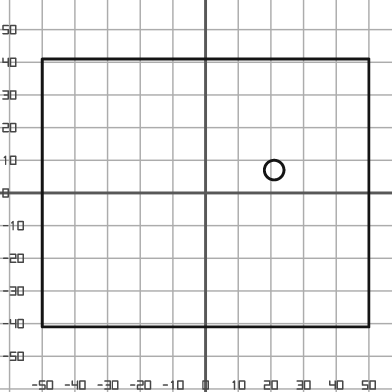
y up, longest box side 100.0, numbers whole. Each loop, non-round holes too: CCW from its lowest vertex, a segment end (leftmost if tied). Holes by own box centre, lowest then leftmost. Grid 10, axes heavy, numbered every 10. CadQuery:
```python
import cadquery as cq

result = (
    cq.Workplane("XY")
    .moveTo(-50.0, -41.0)
    .lineTo(50.0, -41.0)
    .lineTo(50.0, 41.0)
    .lineTo(-50.0, 41.0)
    .close()
    .moveTo(21.0, 7.0)
    .circle(3.0)
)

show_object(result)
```